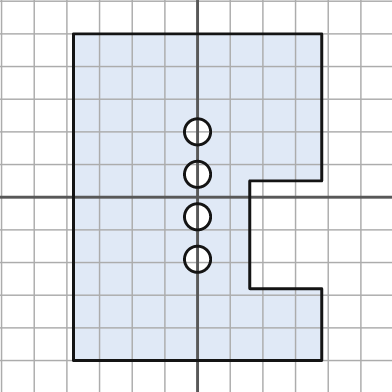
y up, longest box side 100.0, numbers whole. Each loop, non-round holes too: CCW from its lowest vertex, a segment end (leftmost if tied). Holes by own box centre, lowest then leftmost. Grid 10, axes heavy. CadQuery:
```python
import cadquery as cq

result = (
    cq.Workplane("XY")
    .moveTo(-38.0, -50.0)
    .lineTo(38.0, -50.0)
    .lineTo(38.0, -28.0)
    .lineTo(16.0, -28.0)
    .lineTo(16.0, 5.0)
    .lineTo(38.0, 5.0)
    .lineTo(38.0, 50.0)
    .lineTo(-38.0, 50.0)
    .close()
    .moveTo(0.0, -19.0)
    .circle(4.0)
    .moveTo(0.0, -6.0)
    .circle(4.0)
    .moveTo(0.0, 7.0)
    .circle(4.0)
    .moveTo(0.0, 20.0)
    .circle(4.0)
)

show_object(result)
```